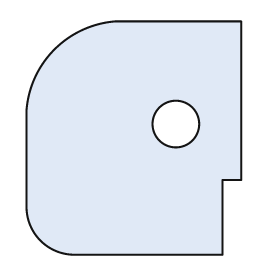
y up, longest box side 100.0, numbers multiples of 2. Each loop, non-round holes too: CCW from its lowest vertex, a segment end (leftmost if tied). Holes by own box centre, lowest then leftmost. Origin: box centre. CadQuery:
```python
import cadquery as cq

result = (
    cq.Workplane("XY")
    .moveTo(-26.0, -50.0)
    .lineTo(38.0, -50.0)
    .lineTo(38.0, -18.0)
    .lineTo(46.0, -18.0)
    .lineTo(46.0, 50.0)
    .lineTo(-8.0, 50.0)
    .threePointArc((-34.0, 38.0), (-46.0, 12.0))
    .lineTo(-46.0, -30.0)
    .threePointArc((-40.0, -44.0), (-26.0, -50.0))
    .close()
    .moveTo(18.0, 6.0)
    .circle(10.0)
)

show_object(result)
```